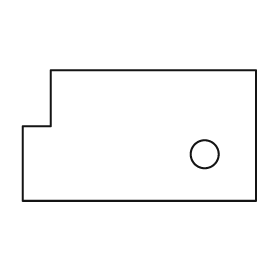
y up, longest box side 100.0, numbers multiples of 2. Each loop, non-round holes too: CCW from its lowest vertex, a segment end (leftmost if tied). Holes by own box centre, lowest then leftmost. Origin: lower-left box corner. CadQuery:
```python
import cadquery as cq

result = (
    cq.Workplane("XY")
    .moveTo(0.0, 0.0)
    .lineTo(100.0, 0.0)
    .lineTo(100.0, 56.0)
    .lineTo(12.0, 56.0)
    .lineTo(12.0, 32.0)
    .lineTo(0.0, 32.0)
    .close()
    .moveTo(78.0, 20.0)
    .circle(6.0)
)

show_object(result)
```